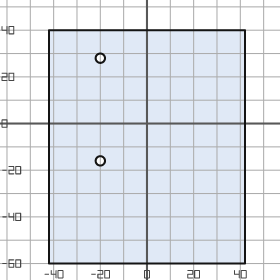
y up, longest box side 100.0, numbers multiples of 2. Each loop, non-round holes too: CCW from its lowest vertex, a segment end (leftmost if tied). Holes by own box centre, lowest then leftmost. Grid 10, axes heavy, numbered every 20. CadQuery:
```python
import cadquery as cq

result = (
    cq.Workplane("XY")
    .moveTo(-42.0, -60.0)
    .lineTo(42.0, -60.0)
    .lineTo(42.0, 40.0)
    .lineTo(-42.0, 40.0)
    .close()
    .moveTo(-20.0, -16.0)
    .circle(2.0)
    .moveTo(-20.0, 28.0)
    .circle(2.0)
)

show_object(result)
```